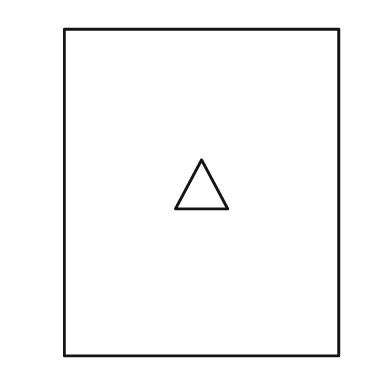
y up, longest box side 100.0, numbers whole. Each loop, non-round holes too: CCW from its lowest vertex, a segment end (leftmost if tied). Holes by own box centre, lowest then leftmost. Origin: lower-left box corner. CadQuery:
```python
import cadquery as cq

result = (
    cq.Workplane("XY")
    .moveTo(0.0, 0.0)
    .lineTo(84.0, 0.0)
    .lineTo(84.0, 100.0)
    .lineTo(0.0, 100.0)
    .close()
    .moveTo(34.0, 45.0)
    .lineTo(50.0, 45.0)
    .lineTo(42.0, 60.0)
    .close()
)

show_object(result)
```